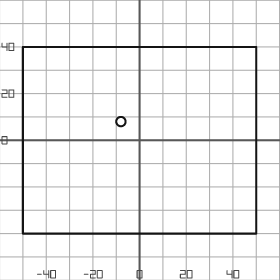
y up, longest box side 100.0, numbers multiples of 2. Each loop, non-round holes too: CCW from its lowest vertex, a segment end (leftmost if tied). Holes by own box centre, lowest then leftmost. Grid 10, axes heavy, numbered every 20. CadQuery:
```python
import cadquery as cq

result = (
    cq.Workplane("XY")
    .moveTo(-50.0, -40.0)
    .lineTo(50.0, -40.0)
    .lineTo(50.0, 40.0)
    .lineTo(-50.0, 40.0)
    .close()
    .moveTo(-8.0, 8.0)
    .circle(2.0)
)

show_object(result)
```